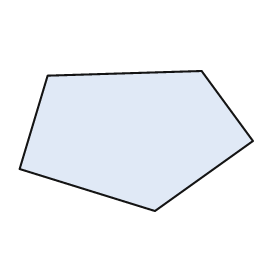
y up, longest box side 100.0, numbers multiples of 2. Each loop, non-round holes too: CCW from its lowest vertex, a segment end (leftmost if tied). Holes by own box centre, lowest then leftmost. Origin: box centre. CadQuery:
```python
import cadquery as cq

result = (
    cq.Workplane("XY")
    .moveTo(8.0, -30.0)
    .lineTo(50.0, 0.0)
    .lineTo(28.0, 30.0)
    .lineTo(-38.0, 28.0)
    .lineTo(-50.0, -12.0)
    .close()
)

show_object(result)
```